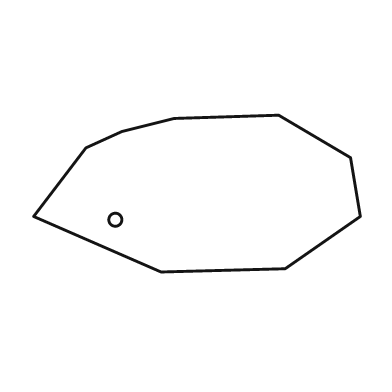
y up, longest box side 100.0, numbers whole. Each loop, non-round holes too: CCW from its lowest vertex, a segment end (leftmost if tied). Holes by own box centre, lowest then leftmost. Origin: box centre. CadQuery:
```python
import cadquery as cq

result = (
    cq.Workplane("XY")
    .moveTo(-11.0, -24.0)
    .lineTo(27.0, -23.0)
    .lineTo(50.0, -7.0)
    .lineTo(47.0, 11.0)
    .lineTo(25.0, 24.0)
    .lineTo(-7.0, 23.0)
    .lineTo(-23.0, 19.0)
    .lineTo(-34.0, 14.0)
    .lineTo(-50.0, -7.0)
    .close()
    .moveTo(-25.0, -8.0)
    .circle(2.0)
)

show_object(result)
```